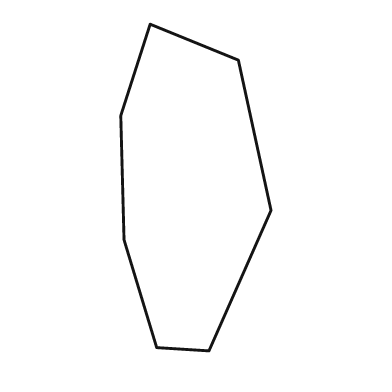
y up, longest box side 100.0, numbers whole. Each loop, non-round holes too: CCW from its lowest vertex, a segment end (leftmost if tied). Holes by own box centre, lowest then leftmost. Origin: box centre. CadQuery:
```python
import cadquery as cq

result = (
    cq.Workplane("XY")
    .moveTo(4.0, -50.0)
    .lineTo(23.0, -7.0)
    .lineTo(13.0, 39.0)
    .lineTo(-14.0, 50.0)
    .lineTo(-23.0, 22.0)
    .lineTo(-22.0, -16.0)
    .lineTo(-12.0, -49.0)
    .close()
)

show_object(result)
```